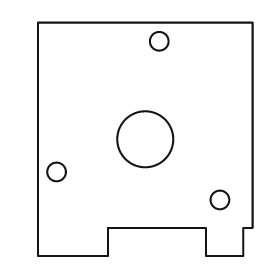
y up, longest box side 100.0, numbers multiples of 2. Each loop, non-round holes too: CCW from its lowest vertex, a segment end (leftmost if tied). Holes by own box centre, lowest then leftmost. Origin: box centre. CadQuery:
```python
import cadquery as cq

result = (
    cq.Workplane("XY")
    .moveTo(-46.0, -50.0)
    .lineTo(-16.0, -50.0)
    .lineTo(-16.0, -38.0)
    .lineTo(26.0, -38.0)
    .lineTo(26.0, -50.0)
    .lineTo(42.0, -50.0)
    .lineTo(42.0, -38.0)
    .lineTo(46.0, -38.0)
    .lineTo(46.0, 50.0)
    .lineTo(-46.0, 50.0)
    .close()
    .moveTo(32.0, -26.0)
    .circle(4.0)
    .moveTo(-38.0, -14.0)
    .circle(4.0)
    .moveTo(0.0, 0.0)
    .circle(12.0)
    .moveTo(6.0, 42.0)
    .circle(4.0)
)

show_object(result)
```